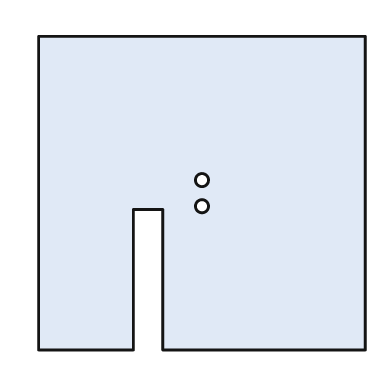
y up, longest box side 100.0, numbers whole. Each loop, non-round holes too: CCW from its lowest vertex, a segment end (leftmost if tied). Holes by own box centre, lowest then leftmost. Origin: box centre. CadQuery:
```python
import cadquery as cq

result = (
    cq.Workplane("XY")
    .moveTo(-50.0, -48.0)
    .lineTo(-21.0, -48.0)
    .lineTo(-21.0, -5.0)
    .lineTo(-12.0, -5.0)
    .lineTo(-12.0, -48.0)
    .lineTo(50.0, -48.0)
    .lineTo(50.0, 48.0)
    .lineTo(-50.0, 48.0)
    .close()
    .moveTo(0.0, -4.0)
    .circle(2.0)
    .moveTo(0.0, 4.0)
    .circle(2.0)
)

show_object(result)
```